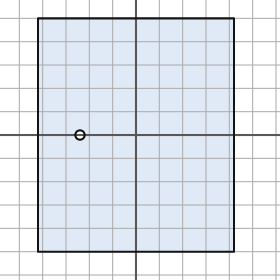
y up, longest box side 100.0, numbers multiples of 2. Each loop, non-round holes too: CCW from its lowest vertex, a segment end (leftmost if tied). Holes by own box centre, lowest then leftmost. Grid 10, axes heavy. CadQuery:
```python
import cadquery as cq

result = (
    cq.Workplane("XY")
    .moveTo(-42.0, -50.0)
    .lineTo(42.0, -50.0)
    .lineTo(42.0, 50.0)
    .lineTo(-42.0, 50.0)
    .close()
    .moveTo(-24.0, 0.0)
    .circle(2.0)
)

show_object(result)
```